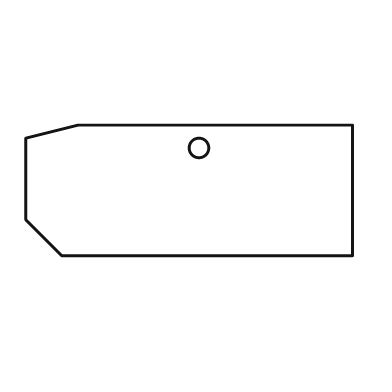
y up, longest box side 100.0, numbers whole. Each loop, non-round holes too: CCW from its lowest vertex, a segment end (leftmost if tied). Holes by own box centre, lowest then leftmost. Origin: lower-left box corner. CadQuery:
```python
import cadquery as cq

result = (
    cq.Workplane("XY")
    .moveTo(11.0, 0.0)
    .lineTo(100.0, 0.0)
    .lineTo(100.0, 40.0)
    .lineTo(16.0, 40.0)
    .lineTo(0.0, 36.0)
    .lineTo(0.0, 11.0)
    .close()
    .moveTo(53.0, 33.0)
    .circle(3.0)
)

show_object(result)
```